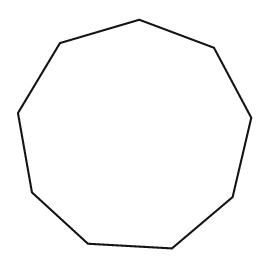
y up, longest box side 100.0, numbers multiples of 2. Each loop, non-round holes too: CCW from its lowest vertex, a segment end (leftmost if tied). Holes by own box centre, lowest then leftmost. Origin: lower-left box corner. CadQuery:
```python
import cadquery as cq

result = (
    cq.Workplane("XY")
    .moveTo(66.0, 0.0)
    .lineTo(92.0, 22.0)
    .lineTo(100.0, 56.0)
    .lineTo(84.0, 86.0)
    .lineTo(52.0, 98.0)
    .lineTo(18.0, 88.0)
    .lineTo(0.0, 58.0)
    .lineTo(6.0, 24.0)
    .lineTo(30.0, 2.0)
    .close()
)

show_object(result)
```